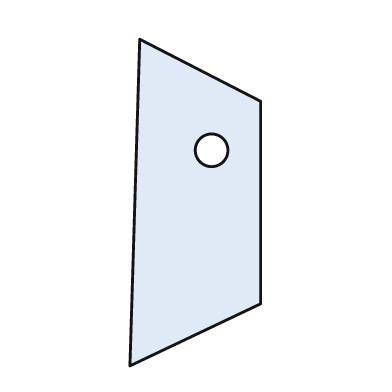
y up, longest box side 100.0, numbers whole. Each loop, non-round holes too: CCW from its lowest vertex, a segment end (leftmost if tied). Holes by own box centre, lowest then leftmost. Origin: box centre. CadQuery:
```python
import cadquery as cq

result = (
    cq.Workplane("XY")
    .moveTo(-20.0, -50.0)
    .lineTo(20.0, -31.0)
    .lineTo(20.0, 31.0)
    .lineTo(-17.0, 50.0)
    .close()
    .moveTo(5.0, 16.0)
    .circle(5.0)
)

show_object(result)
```